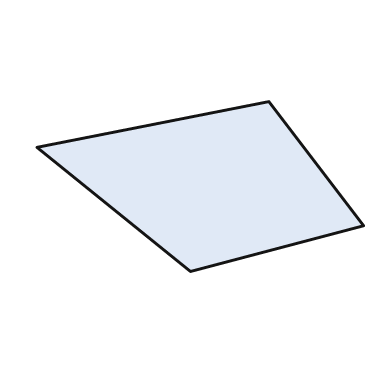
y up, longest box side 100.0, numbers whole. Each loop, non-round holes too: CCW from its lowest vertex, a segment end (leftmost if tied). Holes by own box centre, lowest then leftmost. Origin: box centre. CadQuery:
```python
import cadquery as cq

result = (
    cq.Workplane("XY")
    .moveTo(-3.0, -26.0)
    .lineTo(50.0, -12.0)
    .lineTo(21.0, 26.0)
    .lineTo(-50.0, 12.0)
    .close()
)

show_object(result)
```